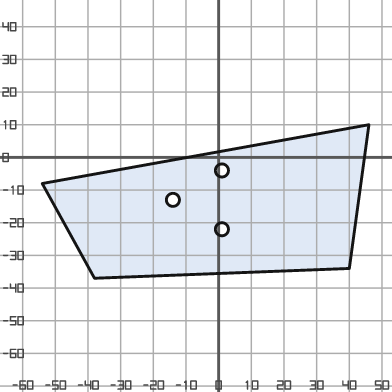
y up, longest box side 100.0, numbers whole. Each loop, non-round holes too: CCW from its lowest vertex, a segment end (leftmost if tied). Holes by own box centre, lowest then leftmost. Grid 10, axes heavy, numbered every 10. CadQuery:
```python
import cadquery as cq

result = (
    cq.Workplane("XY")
    .moveTo(-38.0, -37.0)
    .lineTo(40.0, -34.0)
    .lineTo(46.0, 10.0)
    .lineTo(-54.0, -8.0)
    .close()
    .moveTo(1.0, -22.0)
    .circle(2.0)
    .moveTo(-14.0, -13.0)
    .circle(2.0)
    .moveTo(1.0, -4.0)
    .circle(2.0)
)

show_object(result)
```